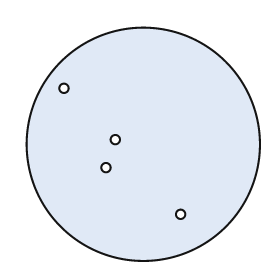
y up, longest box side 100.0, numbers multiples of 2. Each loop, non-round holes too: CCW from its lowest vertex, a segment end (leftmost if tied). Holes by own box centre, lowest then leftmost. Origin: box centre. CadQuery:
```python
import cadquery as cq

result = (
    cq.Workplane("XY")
    .moveTo(0.0, 0.0)
    .circle(50.0)
    .moveTo(16.0, -30.0)
    .circle(2.0)
    .moveTo(-16.0, -10.0)
    .circle(2.0)
    .moveTo(-12.0, 2.0)
    .circle(2.0)
    .moveTo(-34.0, 24.0)
    .circle(2.0)
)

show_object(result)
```